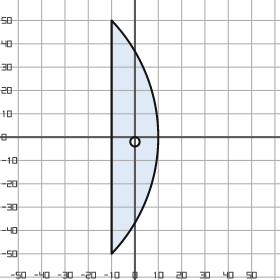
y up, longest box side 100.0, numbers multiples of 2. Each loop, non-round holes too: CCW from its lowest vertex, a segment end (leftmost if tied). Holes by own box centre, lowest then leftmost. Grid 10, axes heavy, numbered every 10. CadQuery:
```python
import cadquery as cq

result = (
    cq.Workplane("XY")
    .moveTo(-10.0, -50.0)
    .threePointArc((10.0, 0.0), (-10.0, 50.0))
    .close()
    .moveTo(0.0, -2.0)
    .circle(2.0)
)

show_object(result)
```